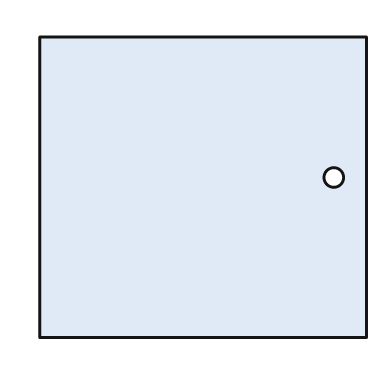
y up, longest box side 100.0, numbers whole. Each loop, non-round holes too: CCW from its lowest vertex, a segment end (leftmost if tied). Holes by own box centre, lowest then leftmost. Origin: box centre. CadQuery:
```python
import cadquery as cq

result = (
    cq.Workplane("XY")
    .moveTo(-50.0, -46.0)
    .lineTo(50.0, -46.0)
    .lineTo(50.0, 46.0)
    .lineTo(-50.0, 46.0)
    .close()
    .moveTo(40.0, 3.0)
    .circle(3.0)
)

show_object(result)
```